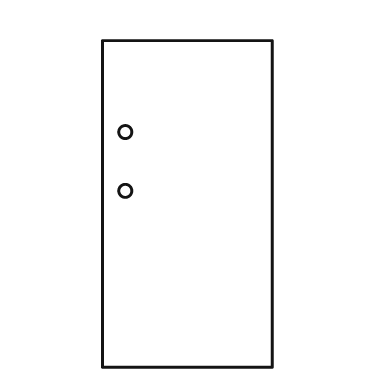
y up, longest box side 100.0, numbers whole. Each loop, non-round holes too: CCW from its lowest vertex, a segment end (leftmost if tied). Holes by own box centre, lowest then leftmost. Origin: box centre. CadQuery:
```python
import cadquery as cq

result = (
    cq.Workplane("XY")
    .moveTo(-26.0, -50.0)
    .lineTo(26.0, -50.0)
    .lineTo(26.0, 50.0)
    .lineTo(-26.0, 50.0)
    .close()
    .moveTo(-19.0, 4.0)
    .circle(2.0)
    .moveTo(-19.0, 22.0)
    .circle(2.0)
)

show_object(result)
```